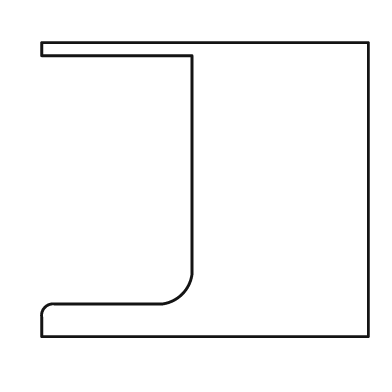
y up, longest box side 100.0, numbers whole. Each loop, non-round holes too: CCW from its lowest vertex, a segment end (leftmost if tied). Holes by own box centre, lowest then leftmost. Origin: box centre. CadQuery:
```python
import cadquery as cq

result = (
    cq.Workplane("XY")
    .moveTo(-50.0, -45.0)
    .lineTo(50.0, -45.0)
    .lineTo(50.0, 45.0)
    .lineTo(-50.0, 45.0)
    .lineTo(-50.0, 41.0)
    .lineTo(-4.0, 41.0)
    .lineTo(-4.0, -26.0)
    .threePointArc((-7.0, -32.0), (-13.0, -35.0))
    .lineTo(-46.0, -35.0)
    .threePointArc((-49.0, -36.0), (-50.0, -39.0))
    .close()
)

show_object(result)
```